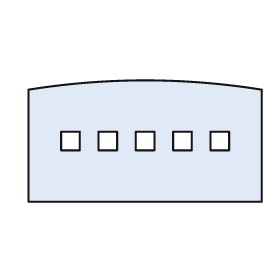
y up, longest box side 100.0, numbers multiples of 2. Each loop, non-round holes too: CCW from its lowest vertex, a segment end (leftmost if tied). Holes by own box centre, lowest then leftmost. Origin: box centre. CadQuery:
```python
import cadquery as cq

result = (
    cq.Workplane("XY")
    .moveTo(-50.0, -26.0)
    .lineTo(50.0, -26.0)
    .lineTo(50.0, 22.0)
    .threePointArc((0.0, 26.0), (-50.0, 22.0))
    .close()
    .moveTo(-36.0, -4.0)
    .lineTo(-28.0, -4.0)
    .lineTo(-28.0, 4.0)
    .lineTo(-36.0, 4.0)
    .close()
    .moveTo(-20.0, -4.0)
    .lineTo(-12.0, -4.0)
    .lineTo(-12.0, 4.0)
    .lineTo(-20.0, 4.0)
    .close()
    .moveTo(-4.0, -4.0)
    .lineTo(4.0, -4.0)
    .lineTo(4.0, 4.0)
    .lineTo(-4.0, 4.0)
    .close()
    .moveTo(12.0, -4.0)
    .lineTo(20.0, -4.0)
    .lineTo(20.0, 4.0)
    .lineTo(12.0, 4.0)
    .close()
    .moveTo(28.0, -4.0)
    .lineTo(36.0, -4.0)
    .lineTo(36.0, 4.0)
    .lineTo(28.0, 4.0)
    .close()
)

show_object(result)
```